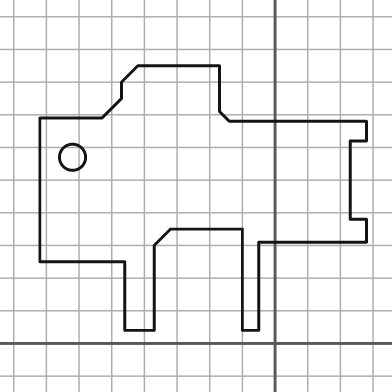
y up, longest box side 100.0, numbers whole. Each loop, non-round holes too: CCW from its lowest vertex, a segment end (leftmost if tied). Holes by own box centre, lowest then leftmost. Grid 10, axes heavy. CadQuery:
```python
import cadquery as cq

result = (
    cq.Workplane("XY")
    .moveTo(-46.0, 4.0)
    .lineTo(-37.0, 4.0)
    .lineTo(-37.0, 30.0)
    .lineTo(-32.0, 35.0)
    .lineTo(-10.0, 35.0)
    .lineTo(-10.0, 4.0)
    .lineTo(-5.0, 4.0)
    .lineTo(-5.0, 31.0)
    .lineTo(28.0, 31.0)
    .lineTo(28.0, 38.0)
    .lineTo(23.0, 38.0)
    .lineTo(23.0, 62.0)
    .lineTo(28.0, 62.0)
    .lineTo(28.0, 68.0)
    .lineTo(-14.0, 68.0)
    .lineTo(-17.0, 71.0)
    .lineTo(-17.0, 85.0)
    .lineTo(-42.0, 85.0)
    .lineTo(-47.0, 80.0)
    .lineTo(-47.0, 75.0)
    .lineTo(-53.0, 69.0)
    .lineTo(-72.0, 69.0)
    .lineTo(-72.0, 25.0)
    .lineTo(-46.0, 25.0)
    .close()
    .moveTo(-62.0, 57.0)
    .circle(4.0)
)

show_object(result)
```